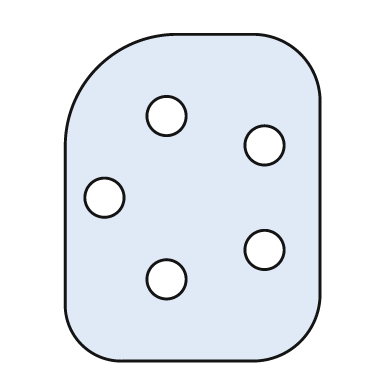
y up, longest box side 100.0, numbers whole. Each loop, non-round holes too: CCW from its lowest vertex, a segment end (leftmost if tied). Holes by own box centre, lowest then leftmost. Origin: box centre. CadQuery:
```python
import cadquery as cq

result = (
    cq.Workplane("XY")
    .moveTo(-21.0, -50.0)
    .lineTo(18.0, -50.0)
    .threePointArc((33.0, -44.0), (39.0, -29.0))
    .lineTo(39.0, 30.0)
    .threePointArc((33.0, 44.0), (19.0, 50.0))
    .lineTo(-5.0, 50.0)
    .threePointArc((-29.0, 40.0), (-39.0, 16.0))
    .lineTo(-39.0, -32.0)
    .threePointArc((-34.0, -45.0), (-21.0, -50.0))
    .close()
    .moveTo(-8.0, -25.0)
    .circle(6.0)
    .moveTo(22.0, -16.0)
    .circle(6.0)
    .moveTo(-27.0, 0.0)
    .circle(6.0)
    .moveTo(22.0, 16.0)
    .circle(6.0)
    .moveTo(-8.0, 25.0)
    .circle(6.0)
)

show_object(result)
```